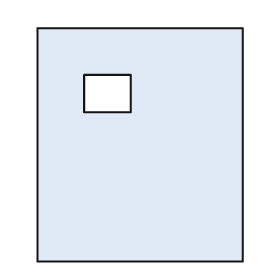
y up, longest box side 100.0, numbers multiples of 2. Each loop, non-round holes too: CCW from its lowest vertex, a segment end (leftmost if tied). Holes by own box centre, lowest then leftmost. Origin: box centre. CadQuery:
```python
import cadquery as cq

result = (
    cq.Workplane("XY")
    .moveTo(-44.0, -50.0)
    .lineTo(44.0, -50.0)
    .lineTo(44.0, 50.0)
    .lineTo(-44.0, 50.0)
    .close()
    .moveTo(-24.0, 14.0)
    .lineTo(-4.0, 14.0)
    .lineTo(-4.0, 30.0)
    .lineTo(-24.0, 30.0)
    .close()
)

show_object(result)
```